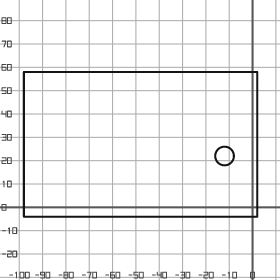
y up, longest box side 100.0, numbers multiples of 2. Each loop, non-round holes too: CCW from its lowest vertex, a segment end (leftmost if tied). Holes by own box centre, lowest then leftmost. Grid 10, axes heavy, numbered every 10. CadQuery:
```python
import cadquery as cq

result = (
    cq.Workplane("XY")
    .moveTo(-98.0, -4.0)
    .lineTo(2.0, -4.0)
    .lineTo(2.0, 58.0)
    .lineTo(-98.0, 58.0)
    .close()
    .moveTo(-12.0, 22.0)
    .circle(4.0)
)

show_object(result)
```